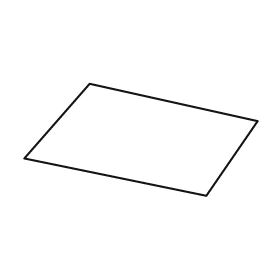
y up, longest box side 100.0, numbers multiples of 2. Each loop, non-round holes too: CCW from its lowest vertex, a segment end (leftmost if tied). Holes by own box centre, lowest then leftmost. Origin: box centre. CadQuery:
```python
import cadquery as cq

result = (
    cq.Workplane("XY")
    .moveTo(28.0, -24.0)
    .lineTo(50.0, 8.0)
    .lineTo(-22.0, 24.0)
    .lineTo(-50.0, -8.0)
    .close()
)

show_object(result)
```